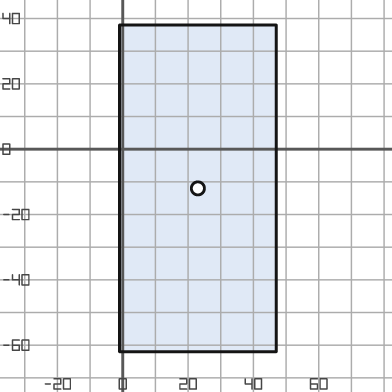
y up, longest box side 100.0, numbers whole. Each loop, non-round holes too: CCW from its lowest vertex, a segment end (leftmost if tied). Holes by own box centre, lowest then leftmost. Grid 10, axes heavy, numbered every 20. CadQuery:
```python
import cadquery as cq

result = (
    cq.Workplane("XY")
    .moveTo(-1.0, -62.0)
    .lineTo(47.0, -62.0)
    .lineTo(47.0, 38.0)
    .lineTo(-1.0, 38.0)
    .close()
    .moveTo(23.0, -12.0)
    .circle(2.0)
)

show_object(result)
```